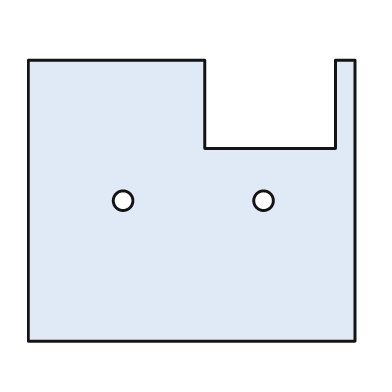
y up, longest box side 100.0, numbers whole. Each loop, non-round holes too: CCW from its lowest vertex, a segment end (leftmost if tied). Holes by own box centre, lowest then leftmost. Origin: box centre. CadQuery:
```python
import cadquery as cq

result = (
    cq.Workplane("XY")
    .moveTo(-50.0, -43.0)
    .lineTo(50.0, -43.0)
    .lineTo(50.0, 43.0)
    .lineTo(44.0, 43.0)
    .lineTo(44.0, 16.0)
    .lineTo(4.0, 16.0)
    .lineTo(4.0, 43.0)
    .lineTo(-50.0, 43.0)
    .close()
    .moveTo(-21.0, 0.0)
    .circle(3.0)
    .moveTo(22.0, 0.0)
    .circle(3.0)
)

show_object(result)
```